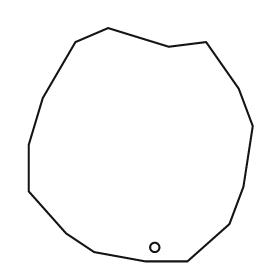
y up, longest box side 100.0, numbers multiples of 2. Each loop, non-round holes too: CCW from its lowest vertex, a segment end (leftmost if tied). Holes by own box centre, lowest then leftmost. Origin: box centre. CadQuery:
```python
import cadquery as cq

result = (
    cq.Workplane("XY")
    .moveTo(2.0, -50.0)
    .lineTo(20.0, -50.0)
    .lineTo(38.0, -34.0)
    .lineTo(44.0, -18.0)
    .lineTo(48.0, 8.0)
    .lineTo(42.0, 24.0)
    .lineTo(28.0, 44.0)
    .lineTo(12.0, 42.0)
    .lineTo(-14.0, 50.0)
    .lineTo(-28.0, 44.0)
    .lineTo(-42.0, 20.0)
    .lineTo(-48.0, 0.0)
    .lineTo(-48.0, -20.0)
    .lineTo(-32.0, -38.0)
    .lineTo(-20.0, -46.0)
    .close()
    .moveTo(6.0, -44.0)
    .circle(2.0)
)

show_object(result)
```